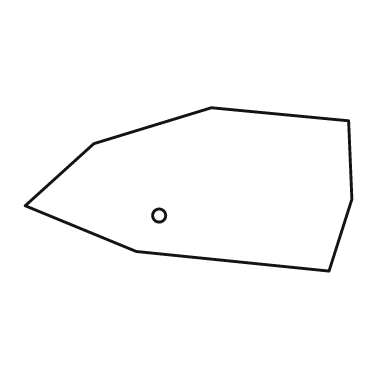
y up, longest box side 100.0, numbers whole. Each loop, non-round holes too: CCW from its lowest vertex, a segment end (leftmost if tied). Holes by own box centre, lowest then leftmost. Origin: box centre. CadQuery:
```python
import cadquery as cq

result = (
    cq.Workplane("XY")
    .moveTo(43.0, -25.0)
    .lineTo(50.0, -3.0)
    .lineTo(49.0, 21.0)
    .lineTo(7.0, 25.0)
    .lineTo(-29.0, 14.0)
    .lineTo(-50.0, -5.0)
    .lineTo(-16.0, -19.0)
    .close()
    .moveTo(-9.0, -8.0)
    .circle(2.0)
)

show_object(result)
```